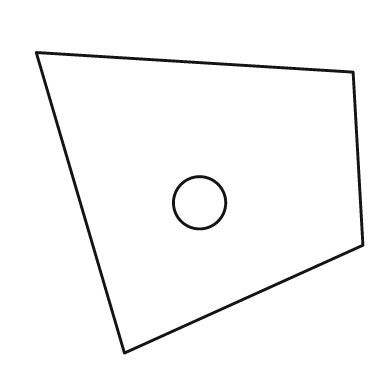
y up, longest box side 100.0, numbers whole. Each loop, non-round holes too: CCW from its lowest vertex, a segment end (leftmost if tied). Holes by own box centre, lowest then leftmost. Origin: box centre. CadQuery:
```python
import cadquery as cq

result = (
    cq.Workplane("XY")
    .moveTo(-23.0, -46.0)
    .lineTo(50.0, -13.0)
    .lineTo(47.0, 40.0)
    .lineTo(-50.0, 46.0)
    .close()
    .moveTo(0.0, 0.0)
    .circle(8.0)
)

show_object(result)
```